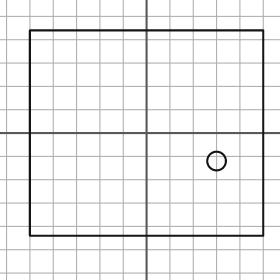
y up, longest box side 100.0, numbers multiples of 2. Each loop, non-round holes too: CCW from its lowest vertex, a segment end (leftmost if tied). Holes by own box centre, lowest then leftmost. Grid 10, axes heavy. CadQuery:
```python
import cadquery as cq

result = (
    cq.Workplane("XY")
    .moveTo(-50.0, -44.0)
    .lineTo(50.0, -44.0)
    .lineTo(50.0, 44.0)
    .lineTo(-50.0, 44.0)
    .close()
    .moveTo(30.0, -12.0)
    .circle(4.0)
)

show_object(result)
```